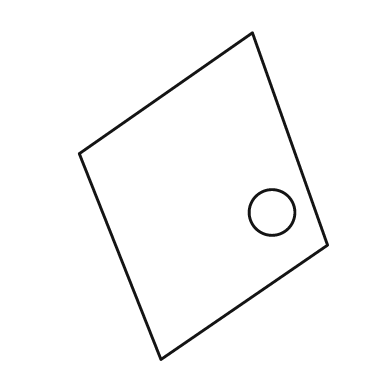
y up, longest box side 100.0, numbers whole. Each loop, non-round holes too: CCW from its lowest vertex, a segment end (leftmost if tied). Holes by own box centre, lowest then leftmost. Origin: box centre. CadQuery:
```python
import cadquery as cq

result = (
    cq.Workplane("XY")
    .moveTo(-13.0, -50.0)
    .lineTo(38.0, -15.0)
    .lineTo(15.0, 50.0)
    .lineTo(-38.0, 13.0)
    .close()
    .moveTo(21.0, -5.0)
    .circle(7.0)
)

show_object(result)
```